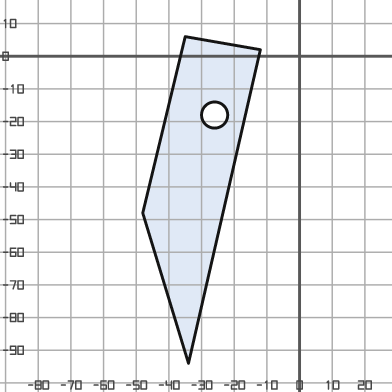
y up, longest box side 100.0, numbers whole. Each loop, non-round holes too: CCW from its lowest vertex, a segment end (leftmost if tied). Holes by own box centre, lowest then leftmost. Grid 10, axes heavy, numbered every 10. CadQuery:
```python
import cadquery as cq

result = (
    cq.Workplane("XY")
    .moveTo(-34.0, -94.0)
    .lineTo(-12.0, 2.0)
    .lineTo(-35.0, 6.0)
    .lineTo(-48.0, -48.0)
    .close()
    .moveTo(-26.0, -18.0)
    .circle(4.0)
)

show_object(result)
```